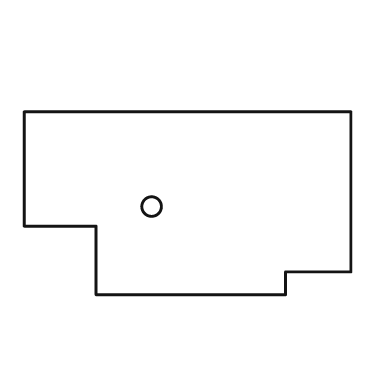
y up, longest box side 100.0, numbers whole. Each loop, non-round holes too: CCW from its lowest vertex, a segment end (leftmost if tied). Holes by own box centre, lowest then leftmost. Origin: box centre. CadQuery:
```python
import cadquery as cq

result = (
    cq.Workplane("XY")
    .moveTo(-28.0, -28.0)
    .lineTo(30.0, -28.0)
    .lineTo(30.0, -21.0)
    .lineTo(50.0, -21.0)
    .lineTo(50.0, 28.0)
    .lineTo(-50.0, 28.0)
    .lineTo(-50.0, -7.0)
    .lineTo(-28.0, -7.0)
    .close()
    .moveTo(-11.0, -1.0)
    .circle(3.0)
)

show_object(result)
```